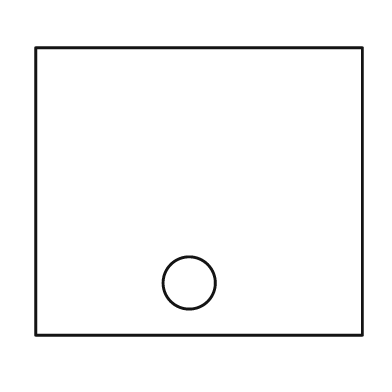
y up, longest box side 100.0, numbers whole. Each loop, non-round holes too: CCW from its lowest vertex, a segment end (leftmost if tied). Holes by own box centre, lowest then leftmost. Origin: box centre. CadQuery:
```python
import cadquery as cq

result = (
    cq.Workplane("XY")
    .moveTo(-50.0, -44.0)
    .lineTo(50.0, -44.0)
    .lineTo(50.0, 44.0)
    .lineTo(-50.0, 44.0)
    .close()
    .moveTo(-3.0, -28.0)
    .circle(8.0)
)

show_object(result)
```